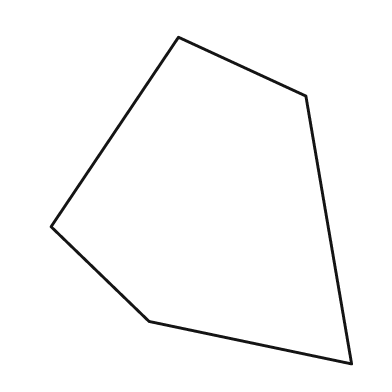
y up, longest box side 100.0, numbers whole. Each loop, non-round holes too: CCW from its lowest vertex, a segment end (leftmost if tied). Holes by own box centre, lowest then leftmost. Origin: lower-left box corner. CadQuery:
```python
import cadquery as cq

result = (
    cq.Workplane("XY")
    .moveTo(92.0, 0.0)
    .lineTo(78.0, 82.0)
    .lineTo(39.0, 100.0)
    .lineTo(0.0, 42.0)
    .lineTo(30.0, 13.0)
    .close()
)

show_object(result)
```